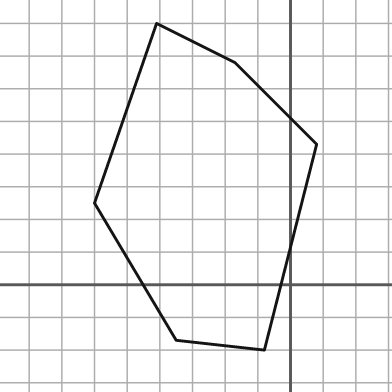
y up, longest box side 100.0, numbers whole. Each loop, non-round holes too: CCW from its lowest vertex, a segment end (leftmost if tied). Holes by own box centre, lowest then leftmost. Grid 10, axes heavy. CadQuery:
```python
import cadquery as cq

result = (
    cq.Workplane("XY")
    .moveTo(-8.0, -20.0)
    .lineTo(8.0, 43.0)
    .lineTo(-17.0, 68.0)
    .lineTo(-41.0, 80.0)
    .lineTo(-60.0, 25.0)
    .lineTo(-35.0, -17.0)
    .close()
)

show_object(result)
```